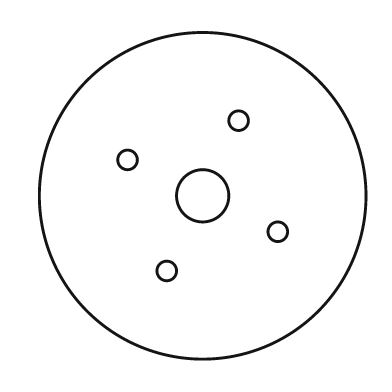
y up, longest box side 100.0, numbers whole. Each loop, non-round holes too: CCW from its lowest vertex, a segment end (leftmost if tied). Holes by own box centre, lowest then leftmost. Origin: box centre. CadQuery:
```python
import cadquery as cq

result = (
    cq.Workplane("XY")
    .moveTo(0.0, 0.0)
    .circle(50.0)
    .moveTo(-11.0, -23.0)
    .circle(3.0)
    .moveTo(23.0, -11.0)
    .circle(3.0)
    .moveTo(0.0, 0.0)
    .circle(8.0)
    .moveTo(-23.0, 11.0)
    .circle(3.0)
    .moveTo(11.0, 23.0)
    .circle(3.0)
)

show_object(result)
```